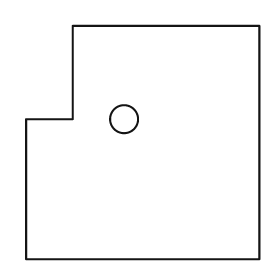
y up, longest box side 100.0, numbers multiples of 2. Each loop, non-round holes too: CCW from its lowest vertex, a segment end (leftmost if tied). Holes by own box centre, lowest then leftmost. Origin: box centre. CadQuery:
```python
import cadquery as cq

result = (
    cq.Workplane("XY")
    .moveTo(-50.0, -50.0)
    .lineTo(50.0, -50.0)
    .lineTo(50.0, 50.0)
    .lineTo(-30.0, 50.0)
    .lineTo(-30.0, 10.0)
    .lineTo(-50.0, 10.0)
    .close()
    .moveTo(-8.0, 10.0)
    .circle(6.0)
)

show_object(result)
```